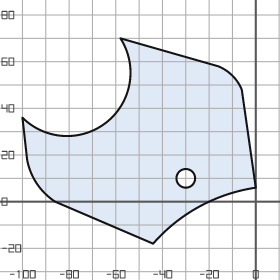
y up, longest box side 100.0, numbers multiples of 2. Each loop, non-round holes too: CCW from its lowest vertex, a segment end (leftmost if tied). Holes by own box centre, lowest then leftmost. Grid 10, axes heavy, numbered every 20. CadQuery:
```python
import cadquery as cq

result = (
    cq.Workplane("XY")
    .moveTo(-44.0, -18.0)
    .threePointArc((-24.0, -2.0), (0.0, 6.0))
    .lineTo(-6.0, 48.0)
    .threePointArc((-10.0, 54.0), (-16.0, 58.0))
    .lineTo(-58.0, 70.0)
    .threePointArc((-64.0, 34.0), (-100.0, 36.0))
    .lineTo(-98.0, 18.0)
    .threePointArc((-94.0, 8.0), (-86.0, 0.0))
    .close()
    .moveTo(-30.0, 10.0)
    .circle(4.0)
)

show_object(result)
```